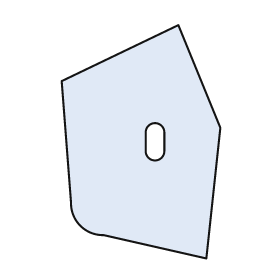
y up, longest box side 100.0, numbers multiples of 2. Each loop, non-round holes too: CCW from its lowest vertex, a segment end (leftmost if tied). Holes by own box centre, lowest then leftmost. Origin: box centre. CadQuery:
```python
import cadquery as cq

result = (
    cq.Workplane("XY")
    .moveTo(28.0, -50.0)
    .lineTo(34.0, 6.0)
    .lineTo(16.0, 50.0)
    .lineTo(-34.0, 26.0)
    .lineTo(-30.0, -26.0)
    .threePointArc((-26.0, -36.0), (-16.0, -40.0))
    .close()
    .moveTo(2.0, -4.0)
    .threePointArc((6.0, -8.0), (10.0, -4.0))
    .lineTo(10.0, 4.0)
    .threePointArc((6.0, 8.0), (2.0, 4.0))
    .close()
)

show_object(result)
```